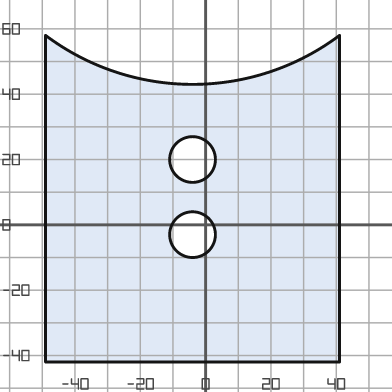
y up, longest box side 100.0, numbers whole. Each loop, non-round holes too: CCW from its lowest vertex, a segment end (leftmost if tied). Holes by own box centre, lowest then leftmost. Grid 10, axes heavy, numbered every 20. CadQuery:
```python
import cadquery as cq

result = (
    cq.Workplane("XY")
    .moveTo(-49.0, -42.0)
    .lineTo(41.0, -42.0)
    .lineTo(41.0, 58.0)
    .threePointArc((-4.0, 43.0), (-49.0, 58.0))
    .close()
    .moveTo(-4.0, -3.0)
    .circle(7.0)
    .moveTo(-4.0, 20.0)
    .circle(7.0)
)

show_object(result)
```